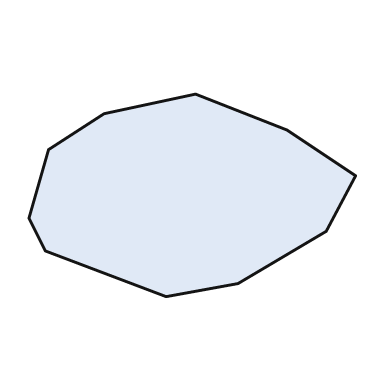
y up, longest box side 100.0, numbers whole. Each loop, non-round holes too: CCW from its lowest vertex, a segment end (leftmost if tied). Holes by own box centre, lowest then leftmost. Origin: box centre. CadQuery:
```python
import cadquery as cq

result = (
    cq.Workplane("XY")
    .moveTo(-8.0, -31.0)
    .lineTo(14.0, -27.0)
    .lineTo(41.0, -11.0)
    .lineTo(50.0, 6.0)
    .lineTo(29.0, 20.0)
    .lineTo(1.0, 31.0)
    .lineTo(-27.0, 25.0)
    .lineTo(-44.0, 14.0)
    .lineTo(-50.0, -7.0)
    .lineTo(-45.0, -17.0)
    .close()
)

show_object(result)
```